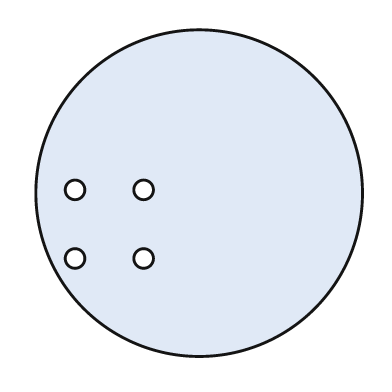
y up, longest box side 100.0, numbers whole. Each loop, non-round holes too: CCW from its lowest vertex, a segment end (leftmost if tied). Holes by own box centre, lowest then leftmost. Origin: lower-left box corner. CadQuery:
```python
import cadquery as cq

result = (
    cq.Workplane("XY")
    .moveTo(50.0, 50.0)
    .circle(50.0)
    .moveTo(12.0, 30.0)
    .circle(3.0)
    .moveTo(33.0, 30.0)
    .circle(3.0)
    .moveTo(12.0, 51.0)
    .circle(3.0)
    .moveTo(33.0, 51.0)
    .circle(3.0)
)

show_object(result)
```